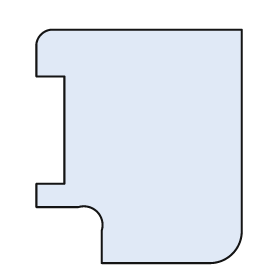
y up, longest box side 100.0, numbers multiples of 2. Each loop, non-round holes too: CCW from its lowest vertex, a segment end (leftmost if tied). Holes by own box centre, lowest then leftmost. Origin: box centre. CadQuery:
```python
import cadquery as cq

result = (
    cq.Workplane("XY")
    .moveTo(-16.0, -50.0)
    .lineTo(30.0, -50.0)
    .threePointArc((40.0, -46.0), (44.0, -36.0))
    .lineTo(44.0, 50.0)
    .lineTo(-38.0, 50.0)
    .threePointArc((-42.0, 48.0), (-44.0, 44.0))
    .lineTo(-44.0, 30.0)
    .lineTo(-32.0, 30.0)
    .lineTo(-32.0, -16.0)
    .lineTo(-44.0, -16.0)
    .lineTo(-44.0, -26.0)
    .lineTo(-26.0, -26.0)
    .threePointArc((-18.0, -28.0), (-16.0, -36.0))
    .close()
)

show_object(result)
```